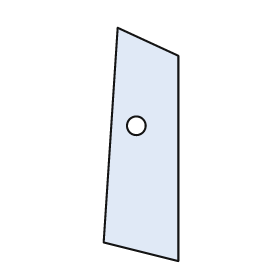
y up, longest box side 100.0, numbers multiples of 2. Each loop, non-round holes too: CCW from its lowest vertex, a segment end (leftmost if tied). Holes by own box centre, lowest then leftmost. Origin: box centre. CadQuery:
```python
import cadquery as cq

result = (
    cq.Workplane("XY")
    .moveTo(16.0, -50.0)
    .lineTo(16.0, 38.0)
    .lineTo(-10.0, 50.0)
    .lineTo(-16.0, -42.0)
    .close()
    .moveTo(-2.0, 8.0)
    .circle(4.0)
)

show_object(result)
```